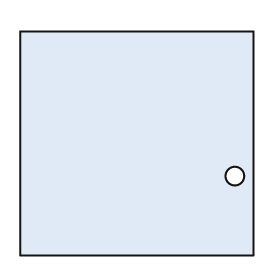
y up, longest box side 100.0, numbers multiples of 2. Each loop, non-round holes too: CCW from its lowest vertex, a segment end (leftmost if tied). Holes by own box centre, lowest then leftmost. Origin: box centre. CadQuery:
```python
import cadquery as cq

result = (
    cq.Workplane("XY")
    .moveTo(-50.0, -48.0)
    .lineTo(50.0, -48.0)
    .lineTo(50.0, 48.0)
    .lineTo(-50.0, 48.0)
    .close()
    .moveTo(42.0, -14.0)
    .circle(4.0)
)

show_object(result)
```